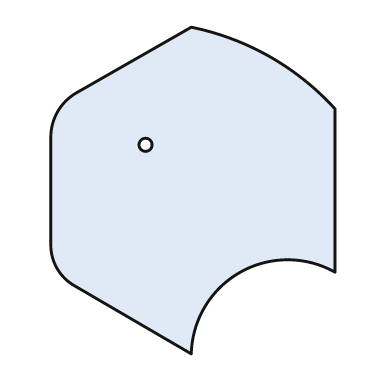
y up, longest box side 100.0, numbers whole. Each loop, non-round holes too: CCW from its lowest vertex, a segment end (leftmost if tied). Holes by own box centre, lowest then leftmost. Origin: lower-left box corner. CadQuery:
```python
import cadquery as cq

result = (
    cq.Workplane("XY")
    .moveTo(43.0, 0.0)
    .threePointArc((58.0, 25.0), (87.0, 25.0))
    .lineTo(87.0, 75.0)
    .threePointArc((67.0, 91.0), (43.0, 100.0))
    .lineTo(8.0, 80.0)
    .threePointArc((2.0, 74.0), (0.0, 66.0))
    .lineTo(0.0, 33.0)
    .threePointArc((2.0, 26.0), (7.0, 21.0))
    .close()
    .moveTo(29.0, 64.0)
    .circle(2.0)
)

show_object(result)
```